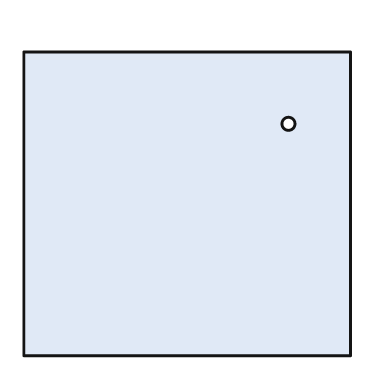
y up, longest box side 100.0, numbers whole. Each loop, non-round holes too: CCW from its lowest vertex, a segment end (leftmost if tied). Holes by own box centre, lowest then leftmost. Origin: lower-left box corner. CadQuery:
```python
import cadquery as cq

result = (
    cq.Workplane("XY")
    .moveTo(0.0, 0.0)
    .lineTo(100.0, 0.0)
    .lineTo(100.0, 93.0)
    .lineTo(0.0, 93.0)
    .close()
    .moveTo(81.0, 71.0)
    .circle(2.0)
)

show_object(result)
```